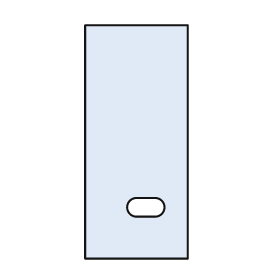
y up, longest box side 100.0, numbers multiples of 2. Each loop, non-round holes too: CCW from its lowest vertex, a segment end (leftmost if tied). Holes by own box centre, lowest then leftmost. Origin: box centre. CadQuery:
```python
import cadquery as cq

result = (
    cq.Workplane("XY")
    .moveTo(-22.0, -50.0)
    .lineTo(22.0, -50.0)
    .lineTo(22.0, 50.0)
    .lineTo(-22.0, 50.0)
    .close()
    .moveTo(0.0, -32.0)
    .lineTo(8.0, -32.0)
    .threePointArc((12.0, -28.0), (8.0, -24.0))
    .lineTo(0.0, -24.0)
    .threePointArc((-4.0, -28.0), (0.0, -32.0))
    .close()
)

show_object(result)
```